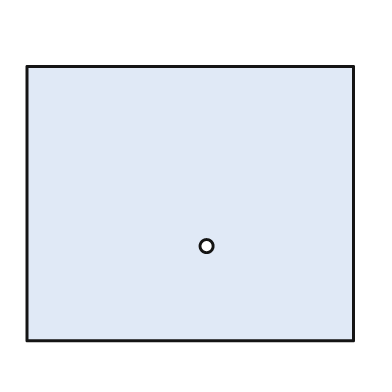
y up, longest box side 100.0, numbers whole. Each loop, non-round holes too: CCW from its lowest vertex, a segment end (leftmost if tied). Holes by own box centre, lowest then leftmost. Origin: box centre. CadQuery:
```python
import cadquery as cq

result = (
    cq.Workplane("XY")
    .moveTo(-50.0, -42.0)
    .lineTo(50.0, -42.0)
    .lineTo(50.0, 42.0)
    .lineTo(-50.0, 42.0)
    .close()
    .moveTo(5.0, -13.0)
    .circle(2.0)
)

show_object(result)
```